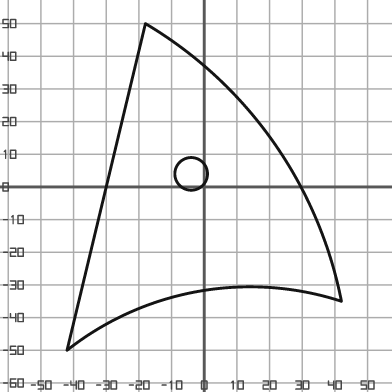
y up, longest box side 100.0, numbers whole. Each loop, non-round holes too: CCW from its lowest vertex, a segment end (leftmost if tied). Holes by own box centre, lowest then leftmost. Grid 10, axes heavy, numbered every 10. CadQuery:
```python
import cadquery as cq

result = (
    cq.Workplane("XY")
    .moveTo(-42.0, -50.0)
    .threePointArc((-2.0, -32.0), (42.0, -35.0))
    .threePointArc((21.0, 14.0), (-18.0, 50.0))
    .close()
    .moveTo(-4.0, 4.0)
    .circle(5.0)
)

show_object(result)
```